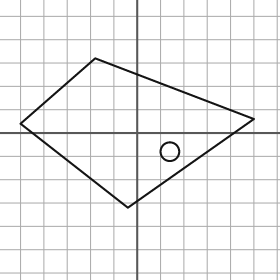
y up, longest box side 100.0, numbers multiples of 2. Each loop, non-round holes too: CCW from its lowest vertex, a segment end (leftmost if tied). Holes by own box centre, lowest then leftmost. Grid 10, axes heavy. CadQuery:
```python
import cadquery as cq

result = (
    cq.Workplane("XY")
    .moveTo(-4.0, -32.0)
    .lineTo(50.0, 6.0)
    .lineTo(-18.0, 32.0)
    .lineTo(-50.0, 4.0)
    .close()
    .moveTo(14.0, -8.0)
    .circle(4.0)
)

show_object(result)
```